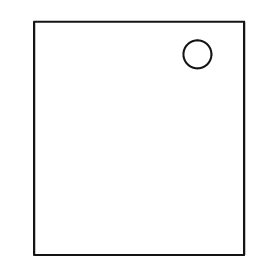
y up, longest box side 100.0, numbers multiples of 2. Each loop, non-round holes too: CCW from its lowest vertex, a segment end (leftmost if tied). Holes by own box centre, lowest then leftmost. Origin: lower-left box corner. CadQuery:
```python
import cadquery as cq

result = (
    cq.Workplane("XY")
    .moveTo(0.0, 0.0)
    .lineTo(90.0, 0.0)
    .lineTo(90.0, 100.0)
    .lineTo(0.0, 100.0)
    .close()
    .moveTo(70.0, 86.0)
    .circle(6.0)
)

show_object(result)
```